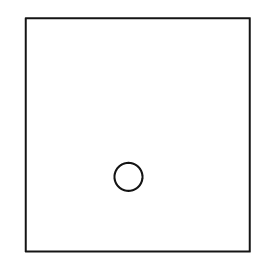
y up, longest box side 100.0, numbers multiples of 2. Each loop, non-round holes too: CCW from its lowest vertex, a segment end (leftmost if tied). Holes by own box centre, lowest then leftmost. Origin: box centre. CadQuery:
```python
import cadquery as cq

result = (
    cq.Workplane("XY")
    .moveTo(-48.0, -50.0)
    .lineTo(48.0, -50.0)
    .lineTo(48.0, 50.0)
    .lineTo(-48.0, 50.0)
    .close()
    .moveTo(-4.0, -18.0)
    .circle(6.0)
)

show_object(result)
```